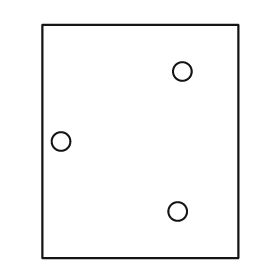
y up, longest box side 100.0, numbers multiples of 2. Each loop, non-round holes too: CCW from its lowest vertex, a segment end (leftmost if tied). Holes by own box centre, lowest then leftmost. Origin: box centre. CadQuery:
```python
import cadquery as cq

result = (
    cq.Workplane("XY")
    .moveTo(-42.0, -50.0)
    .lineTo(42.0, -50.0)
    .lineTo(42.0, 50.0)
    .lineTo(-42.0, 50.0)
    .close()
    .moveTo(16.0, -30.0)
    .circle(4.0)
    .moveTo(-34.0, 0.0)
    .circle(4.0)
    .moveTo(18.0, 30.0)
    .circle(4.0)
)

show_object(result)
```